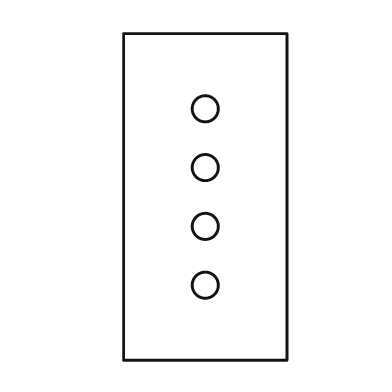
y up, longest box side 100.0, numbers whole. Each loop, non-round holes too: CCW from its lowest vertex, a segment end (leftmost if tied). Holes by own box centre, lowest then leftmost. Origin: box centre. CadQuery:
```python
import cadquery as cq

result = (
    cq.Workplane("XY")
    .moveTo(-25.0, -50.0)
    .lineTo(25.0, -50.0)
    .lineTo(25.0, 50.0)
    .lineTo(-25.0, 50.0)
    .close()
    .moveTo(0.0, -27.0)
    .circle(4.0)
    .moveTo(0.0, -9.0)
    .circle(4.0)
    .moveTo(0.0, 9.0)
    .circle(4.0)
    .moveTo(0.0, 27.0)
    .circle(4.0)
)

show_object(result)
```